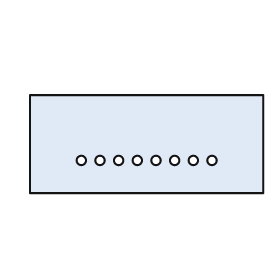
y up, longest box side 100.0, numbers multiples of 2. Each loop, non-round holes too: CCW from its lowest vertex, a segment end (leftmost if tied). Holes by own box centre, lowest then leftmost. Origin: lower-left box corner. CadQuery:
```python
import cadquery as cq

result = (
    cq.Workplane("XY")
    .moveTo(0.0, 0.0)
    .lineTo(100.0, 0.0)
    .lineTo(100.0, 42.0)
    .lineTo(0.0, 42.0)
    .close()
    .moveTo(22.0, 14.0)
    .circle(2.0)
    .moveTo(30.0, 14.0)
    .circle(2.0)
    .moveTo(38.0, 14.0)
    .circle(2.0)
    .moveTo(46.0, 14.0)
    .circle(2.0)
    .moveTo(54.0, 14.0)
    .circle(2.0)
    .moveTo(62.0, 14.0)
    .circle(2.0)
    .moveTo(70.0, 14.0)
    .circle(2.0)
    .moveTo(78.0, 14.0)
    .circle(2.0)
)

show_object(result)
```